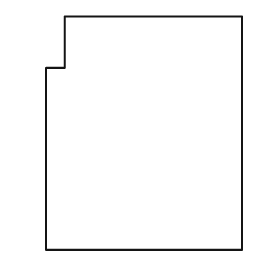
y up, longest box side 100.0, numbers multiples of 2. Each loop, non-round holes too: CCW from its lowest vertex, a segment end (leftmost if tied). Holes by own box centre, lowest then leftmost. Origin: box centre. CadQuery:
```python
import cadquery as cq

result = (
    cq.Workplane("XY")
    .moveTo(-42.0, -50.0)
    .lineTo(42.0, -50.0)
    .lineTo(42.0, 50.0)
    .lineTo(-34.0, 50.0)
    .lineTo(-34.0, 28.0)
    .lineTo(-42.0, 28.0)
    .close()
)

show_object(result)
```